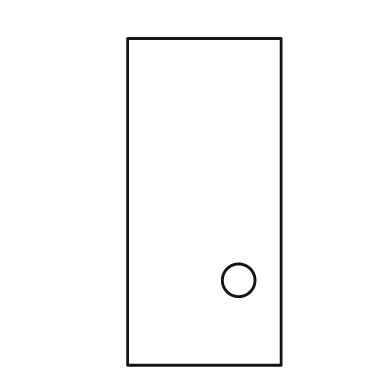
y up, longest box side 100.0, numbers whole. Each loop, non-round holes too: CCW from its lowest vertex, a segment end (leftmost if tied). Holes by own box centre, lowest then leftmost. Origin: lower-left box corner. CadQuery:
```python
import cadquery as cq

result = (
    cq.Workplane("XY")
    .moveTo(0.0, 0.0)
    .lineTo(47.0, 0.0)
    .lineTo(47.0, 100.0)
    .lineTo(0.0, 100.0)
    .close()
    .moveTo(34.0, 26.0)
    .circle(5.0)
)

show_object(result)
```